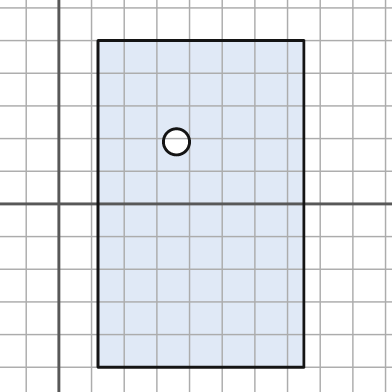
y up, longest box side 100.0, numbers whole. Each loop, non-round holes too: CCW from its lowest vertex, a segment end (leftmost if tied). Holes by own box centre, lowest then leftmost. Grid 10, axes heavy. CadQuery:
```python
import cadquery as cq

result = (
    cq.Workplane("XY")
    .moveTo(12.0, -50.0)
    .lineTo(75.0, -50.0)
    .lineTo(75.0, 50.0)
    .lineTo(12.0, 50.0)
    .close()
    .moveTo(36.0, 19.0)
    .circle(4.0)
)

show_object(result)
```